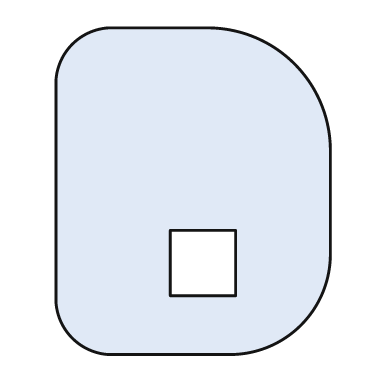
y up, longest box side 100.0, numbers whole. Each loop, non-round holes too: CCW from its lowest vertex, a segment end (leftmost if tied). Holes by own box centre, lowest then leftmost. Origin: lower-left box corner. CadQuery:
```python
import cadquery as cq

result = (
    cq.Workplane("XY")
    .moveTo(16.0, 0.0)
    .lineTo(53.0, 0.0)
    .threePointArc((75.0, 9.0), (84.0, 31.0))
    .lineTo(84.0, 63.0)
    .threePointArc((73.0, 89.0), (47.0, 100.0))
    .lineTo(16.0, 100.0)
    .threePointArc((5.0, 95.0), (0.0, 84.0))
    .lineTo(0.0, 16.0)
    .threePointArc((5.0, 5.0), (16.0, 0.0))
    .close()
    .moveTo(35.0, 18.0)
    .lineTo(55.0, 18.0)
    .lineTo(55.0, 38.0)
    .lineTo(35.0, 38.0)
    .close()
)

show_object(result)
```